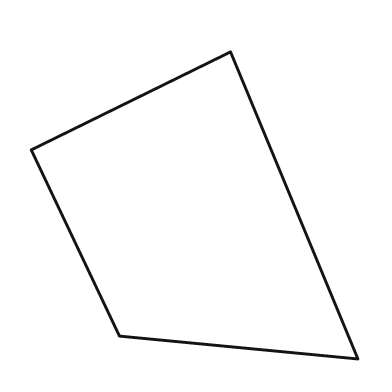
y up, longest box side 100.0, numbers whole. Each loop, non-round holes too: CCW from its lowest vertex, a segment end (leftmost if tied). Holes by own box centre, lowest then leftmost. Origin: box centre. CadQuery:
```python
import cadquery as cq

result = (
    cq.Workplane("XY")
    .moveTo(50.0, -47.0)
    .lineTo(11.0, 47.0)
    .lineTo(-50.0, 17.0)
    .lineTo(-23.0, -40.0)
    .close()
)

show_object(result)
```